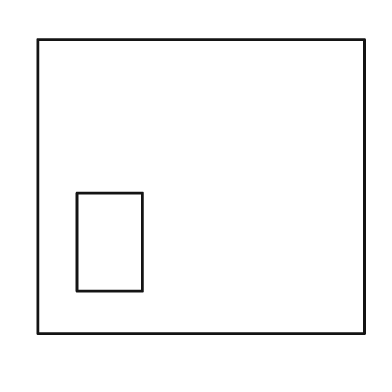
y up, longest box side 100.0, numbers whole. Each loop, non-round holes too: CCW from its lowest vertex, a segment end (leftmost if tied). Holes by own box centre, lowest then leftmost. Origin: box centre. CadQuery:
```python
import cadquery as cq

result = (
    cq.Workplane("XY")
    .moveTo(-50.0, -45.0)
    .lineTo(50.0, -45.0)
    .lineTo(50.0, 45.0)
    .lineTo(-50.0, 45.0)
    .close()
    .moveTo(-38.0, -32.0)
    .lineTo(-18.0, -32.0)
    .lineTo(-18.0, -2.0)
    .lineTo(-38.0, -2.0)
    .close()
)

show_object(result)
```